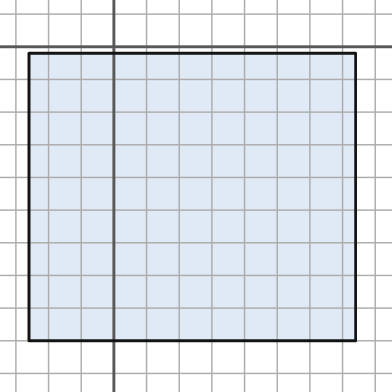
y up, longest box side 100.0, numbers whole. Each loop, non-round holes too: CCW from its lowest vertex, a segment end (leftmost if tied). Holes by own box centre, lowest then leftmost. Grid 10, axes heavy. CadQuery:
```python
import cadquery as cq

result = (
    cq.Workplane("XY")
    .moveTo(-26.0, -90.0)
    .lineTo(74.0, -90.0)
    .lineTo(74.0, -2.0)
    .lineTo(-26.0, -2.0)
    .close()
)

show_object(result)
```